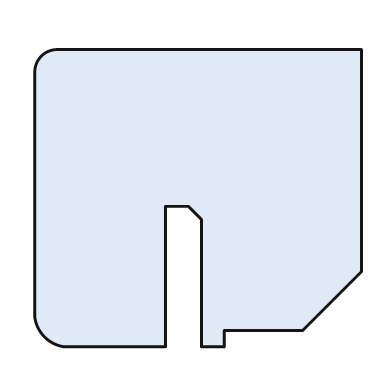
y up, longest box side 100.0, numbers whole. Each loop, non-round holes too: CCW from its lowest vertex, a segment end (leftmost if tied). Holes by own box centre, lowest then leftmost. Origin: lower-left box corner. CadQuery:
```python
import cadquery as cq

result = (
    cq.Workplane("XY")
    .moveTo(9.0, 0.0)
    .lineTo(40.0, 0.0)
    .lineTo(40.0, 43.0)
    .lineTo(47.0, 43.0)
    .lineTo(51.0, 39.0)
    .lineTo(51.0, 0.0)
    .lineTo(58.0, 0.0)
    .lineTo(58.0, 5.0)
    .lineTo(82.0, 5.0)
    .lineTo(100.0, 23.0)
    .lineTo(100.0, 91.0)
    .lineTo(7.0, 91.0)
    .threePointArc((2.0, 89.0), (0.0, 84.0))
    .lineTo(0.0, 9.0)
    .threePointArc((3.0, 3.0), (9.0, 0.0))
    .close()
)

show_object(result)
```